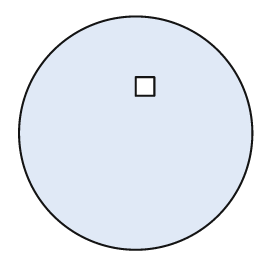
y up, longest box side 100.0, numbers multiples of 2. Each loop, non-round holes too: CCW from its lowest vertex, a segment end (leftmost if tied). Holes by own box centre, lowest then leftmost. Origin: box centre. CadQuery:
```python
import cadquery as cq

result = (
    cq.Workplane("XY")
    .moveTo(0.0, 0.0)
    .circle(50.0)
    .moveTo(0.0, 16.0)
    .lineTo(8.0, 16.0)
    .lineTo(8.0, 24.0)
    .lineTo(0.0, 24.0)
    .close()
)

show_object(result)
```